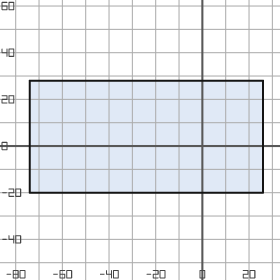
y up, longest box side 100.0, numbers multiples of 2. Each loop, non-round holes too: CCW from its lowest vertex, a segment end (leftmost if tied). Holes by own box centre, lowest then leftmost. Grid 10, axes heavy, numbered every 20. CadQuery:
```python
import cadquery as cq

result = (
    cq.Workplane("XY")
    .moveTo(-74.0, -20.0)
    .lineTo(26.0, -20.0)
    .lineTo(26.0, 28.0)
    .lineTo(-74.0, 28.0)
    .close()
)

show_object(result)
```